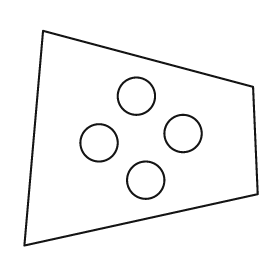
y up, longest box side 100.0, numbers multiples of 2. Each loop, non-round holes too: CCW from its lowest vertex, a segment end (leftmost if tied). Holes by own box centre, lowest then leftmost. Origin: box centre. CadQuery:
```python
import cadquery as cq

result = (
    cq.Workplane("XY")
    .moveTo(-50.0, -46.0)
    .lineTo(50.0, -24.0)
    .lineTo(48.0, 22.0)
    .lineTo(-42.0, 46.0)
    .close()
    .moveTo(2.0, -18.0)
    .circle(8.0)
    .moveTo(-18.0, -2.0)
    .circle(8.0)
    .moveTo(18.0, 2.0)
    .circle(8.0)
    .moveTo(-2.0, 18.0)
    .circle(8.0)
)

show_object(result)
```